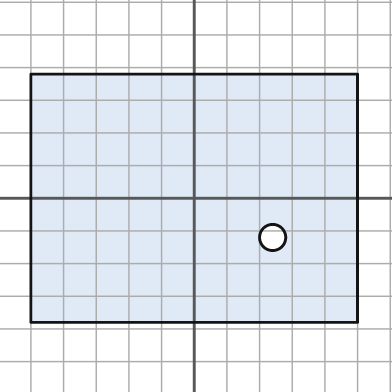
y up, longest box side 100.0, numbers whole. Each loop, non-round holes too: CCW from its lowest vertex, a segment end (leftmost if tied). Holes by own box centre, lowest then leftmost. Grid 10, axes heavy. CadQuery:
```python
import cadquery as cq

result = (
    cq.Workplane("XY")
    .moveTo(-50.0, -38.0)
    .lineTo(50.0, -38.0)
    .lineTo(50.0, 38.0)
    .lineTo(-50.0, 38.0)
    .close()
    .moveTo(24.0, -12.0)
    .circle(4.0)
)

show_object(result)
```